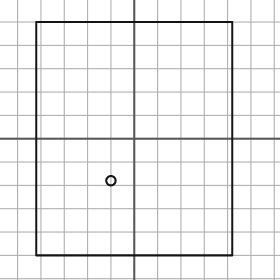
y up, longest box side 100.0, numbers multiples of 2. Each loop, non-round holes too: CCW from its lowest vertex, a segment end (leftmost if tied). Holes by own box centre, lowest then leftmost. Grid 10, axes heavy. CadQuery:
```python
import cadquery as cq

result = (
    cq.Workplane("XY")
    .moveTo(-42.0, -50.0)
    .lineTo(42.0, -50.0)
    .lineTo(42.0, 50.0)
    .lineTo(-42.0, 50.0)
    .close()
    .moveTo(-10.0, -18.0)
    .circle(2.0)
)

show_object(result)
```